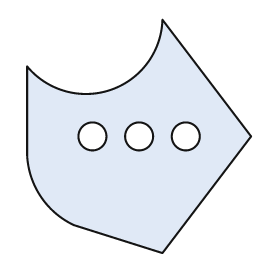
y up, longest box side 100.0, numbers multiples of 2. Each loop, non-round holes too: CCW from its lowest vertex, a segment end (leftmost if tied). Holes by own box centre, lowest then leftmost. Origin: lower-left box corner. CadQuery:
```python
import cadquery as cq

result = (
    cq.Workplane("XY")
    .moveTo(58.0, 0.0)
    .lineTo(96.0, 50.0)
    .lineTo(58.0, 100.0)
    .threePointArc((36.0, 70.0), (0.0, 80.0))
    .lineTo(0.0, 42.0)
    .threePointArc((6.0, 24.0), (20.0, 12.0))
    .close()
    .moveTo(28.0, 50.0)
    .circle(6.0)
    .moveTo(48.0, 50.0)
    .circle(6.0)
    .moveTo(68.0, 50.0)
    .circle(6.0)
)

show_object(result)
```